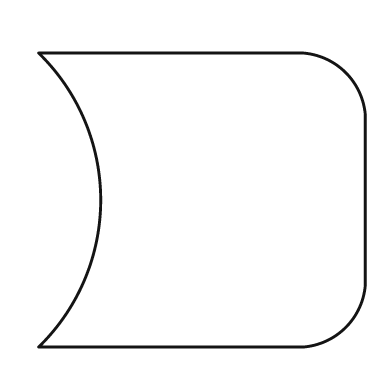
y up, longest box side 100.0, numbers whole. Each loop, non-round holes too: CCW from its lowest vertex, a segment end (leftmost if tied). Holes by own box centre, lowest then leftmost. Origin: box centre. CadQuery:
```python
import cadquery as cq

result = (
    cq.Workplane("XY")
    .moveTo(-50.0, -45.0)
    .lineTo(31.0, -45.0)
    .threePointArc((44.0, -39.0), (50.0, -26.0))
    .lineTo(50.0, 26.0)
    .threePointArc((44.0, 39.0), (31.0, 45.0))
    .lineTo(-50.0, 45.0)
    .threePointArc((-31.0, 0.0), (-50.0, -45.0))
    .close()
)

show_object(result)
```